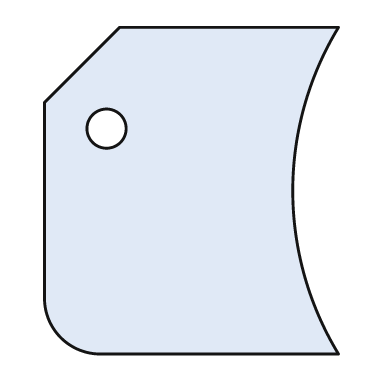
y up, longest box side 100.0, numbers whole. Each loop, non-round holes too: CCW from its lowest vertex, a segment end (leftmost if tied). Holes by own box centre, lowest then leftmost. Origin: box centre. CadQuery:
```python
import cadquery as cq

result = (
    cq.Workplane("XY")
    .moveTo(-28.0, -50.0)
    .lineTo(45.0, -50.0)
    .threePointArc((31.0, 0.0), (45.0, 50.0))
    .lineTo(-22.0, 50.0)
    .lineTo(-45.0, 27.0)
    .lineTo(-45.0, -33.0)
    .threePointArc((-40.0, -45.0), (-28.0, -50.0))
    .close()
    .moveTo(-26.0, 19.0)
    .circle(6.0)
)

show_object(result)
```